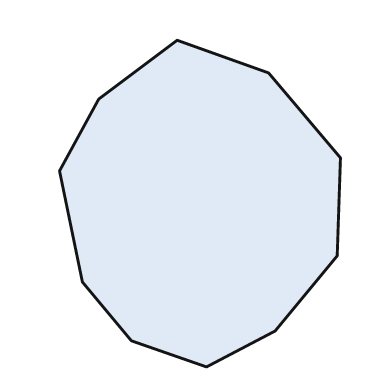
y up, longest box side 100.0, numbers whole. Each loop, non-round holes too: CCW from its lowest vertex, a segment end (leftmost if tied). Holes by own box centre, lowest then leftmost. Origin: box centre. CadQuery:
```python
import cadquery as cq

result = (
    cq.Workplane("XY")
    .moveTo(2.0, -50.0)
    .lineTo(23.0, -39.0)
    .lineTo(42.0, -16.0)
    .lineTo(43.0, 14.0)
    .lineTo(21.0, 40.0)
    .lineTo(-7.0, 50.0)
    .lineTo(-31.0, 32.0)
    .lineTo(-43.0, 10.0)
    .lineTo(-36.0, -24.0)
    .lineTo(-21.0, -42.0)
    .close()
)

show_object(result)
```